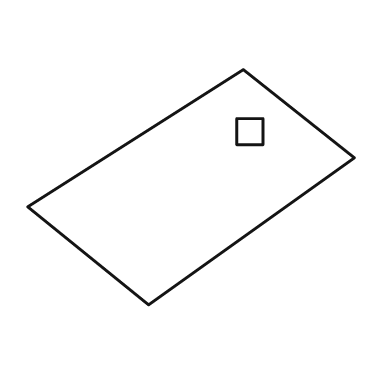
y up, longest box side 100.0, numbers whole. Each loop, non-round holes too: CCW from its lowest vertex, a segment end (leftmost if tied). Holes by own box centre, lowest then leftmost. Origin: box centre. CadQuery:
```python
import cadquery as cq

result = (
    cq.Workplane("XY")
    .moveTo(-13.0, -36.0)
    .lineTo(50.0, 9.0)
    .lineTo(16.0, 36.0)
    .lineTo(-50.0, -6.0)
    .close()
    .moveTo(14.0, 13.0)
    .lineTo(22.0, 13.0)
    .lineTo(22.0, 21.0)
    .lineTo(14.0, 21.0)
    .close()
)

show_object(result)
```